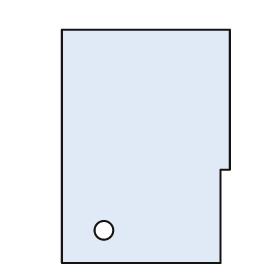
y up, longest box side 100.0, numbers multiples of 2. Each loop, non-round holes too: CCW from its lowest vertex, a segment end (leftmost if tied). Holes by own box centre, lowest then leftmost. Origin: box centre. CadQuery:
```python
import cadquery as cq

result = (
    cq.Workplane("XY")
    .moveTo(-36.0, -50.0)
    .lineTo(32.0, -50.0)
    .lineTo(32.0, -10.0)
    .lineTo(36.0, -10.0)
    .lineTo(36.0, 50.0)
    .lineTo(-36.0, 50.0)
    .close()
    .moveTo(-18.0, -36.0)
    .circle(4.0)
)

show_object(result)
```